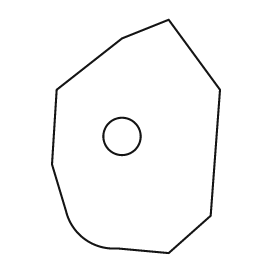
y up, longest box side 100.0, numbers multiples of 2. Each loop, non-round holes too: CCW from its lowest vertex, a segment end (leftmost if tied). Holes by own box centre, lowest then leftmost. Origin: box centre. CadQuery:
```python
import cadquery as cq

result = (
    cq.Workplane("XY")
    .moveTo(14.0, -50.0)
    .lineTo(32.0, -34.0)
    .lineTo(36.0, 20.0)
    .lineTo(14.0, 50.0)
    .lineTo(-6.0, 42.0)
    .lineTo(-34.0, 20.0)
    .lineTo(-36.0, -12.0)
    .lineTo(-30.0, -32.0)
    .threePointArc((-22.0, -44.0), (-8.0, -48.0))
    .close()
    .moveTo(-6.0, 0.0)
    .circle(8.0)
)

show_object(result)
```